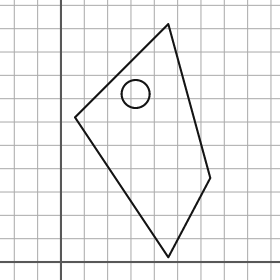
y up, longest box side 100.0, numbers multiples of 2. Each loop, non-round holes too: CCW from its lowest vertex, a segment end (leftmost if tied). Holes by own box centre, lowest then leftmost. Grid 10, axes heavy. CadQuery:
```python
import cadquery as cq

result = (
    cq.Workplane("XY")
    .moveTo(46.0, 2.0)
    .lineTo(64.0, 36.0)
    .lineTo(46.0, 102.0)
    .lineTo(6.0, 62.0)
    .close()
    .moveTo(32.0, 72.0)
    .circle(6.0)
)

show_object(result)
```